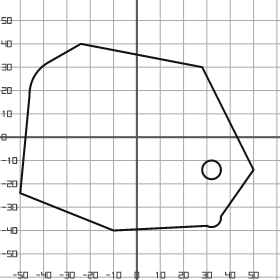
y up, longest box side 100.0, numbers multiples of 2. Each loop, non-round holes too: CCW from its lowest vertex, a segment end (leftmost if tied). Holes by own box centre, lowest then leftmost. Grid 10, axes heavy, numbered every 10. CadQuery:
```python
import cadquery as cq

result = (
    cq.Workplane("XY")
    .moveTo(-10.0, -40.0)
    .lineTo(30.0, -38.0)
    .threePointArc((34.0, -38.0), (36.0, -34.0))
    .lineTo(50.0, -14.0)
    .lineTo(28.0, 30.0)
    .lineTo(-24.0, 40.0)
    .lineTo(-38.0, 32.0)
    .threePointArc((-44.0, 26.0), (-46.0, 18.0))
    .lineTo(-50.0, -24.0)
    .close()
    .moveTo(32.0, -14.0)
    .circle(4.0)
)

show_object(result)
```